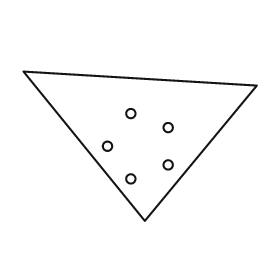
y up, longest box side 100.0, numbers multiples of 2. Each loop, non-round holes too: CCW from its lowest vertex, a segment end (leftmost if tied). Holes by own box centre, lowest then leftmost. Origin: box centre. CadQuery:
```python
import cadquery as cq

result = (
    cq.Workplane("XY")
    .moveTo(2.0, -32.0)
    .lineTo(50.0, 26.0)
    .lineTo(-50.0, 32.0)
    .close()
    .moveTo(-4.0, -14.0)
    .circle(2.0)
    .moveTo(12.0, -8.0)
    .circle(2.0)
    .moveTo(-14.0, 0.0)
    .circle(2.0)
    .moveTo(12.0, 8.0)
    .circle(2.0)
    .moveTo(-4.0, 14.0)
    .circle(2.0)
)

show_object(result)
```